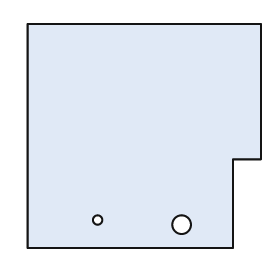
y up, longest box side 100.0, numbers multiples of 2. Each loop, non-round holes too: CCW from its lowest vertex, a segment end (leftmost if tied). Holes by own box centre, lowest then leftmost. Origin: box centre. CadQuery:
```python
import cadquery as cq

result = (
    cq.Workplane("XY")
    .moveTo(-50.0, -48.0)
    .lineTo(38.0, -48.0)
    .lineTo(38.0, -10.0)
    .lineTo(50.0, -10.0)
    .lineTo(50.0, 48.0)
    .lineTo(-50.0, 48.0)
    .close()
    .moveTo(16.0, -38.0)
    .circle(4.0)
    .moveTo(-20.0, -36.0)
    .circle(2.0)
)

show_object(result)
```